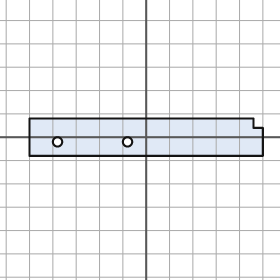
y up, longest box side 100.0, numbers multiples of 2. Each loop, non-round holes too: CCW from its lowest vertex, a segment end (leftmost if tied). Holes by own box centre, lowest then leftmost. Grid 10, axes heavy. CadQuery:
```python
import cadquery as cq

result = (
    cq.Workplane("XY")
    .moveTo(-50.0, -8.0)
    .lineTo(50.0, -8.0)
    .lineTo(50.0, 4.0)
    .lineTo(46.0, 4.0)
    .lineTo(46.0, 8.0)
    .lineTo(-50.0, 8.0)
    .close()
    .moveTo(-38.0, -2.0)
    .circle(2.0)
    .moveTo(-8.0, -2.0)
    .circle(2.0)
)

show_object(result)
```